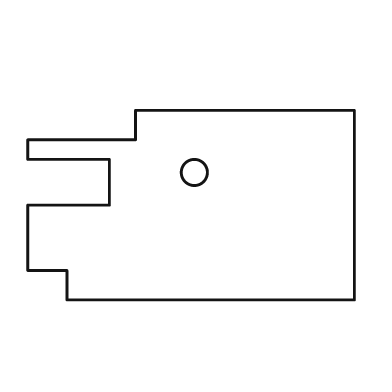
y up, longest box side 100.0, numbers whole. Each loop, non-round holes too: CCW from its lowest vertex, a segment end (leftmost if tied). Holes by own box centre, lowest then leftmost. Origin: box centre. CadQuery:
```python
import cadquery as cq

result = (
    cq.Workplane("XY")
    .moveTo(-38.0, -29.0)
    .lineTo(50.0, -29.0)
    .lineTo(50.0, 29.0)
    .lineTo(-17.0, 29.0)
    .lineTo(-17.0, 20.0)
    .lineTo(-50.0, 20.0)
    .lineTo(-50.0, 14.0)
    .lineTo(-25.0, 14.0)
    .lineTo(-25.0, 0.0)
    .lineTo(-50.0, 0.0)
    .lineTo(-50.0, -20.0)
    .lineTo(-38.0, -20.0)
    .close()
    .moveTo(1.0, 10.0)
    .circle(4.0)
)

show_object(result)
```